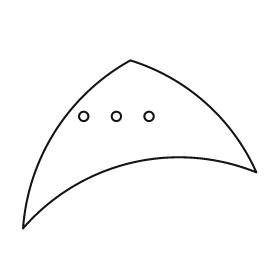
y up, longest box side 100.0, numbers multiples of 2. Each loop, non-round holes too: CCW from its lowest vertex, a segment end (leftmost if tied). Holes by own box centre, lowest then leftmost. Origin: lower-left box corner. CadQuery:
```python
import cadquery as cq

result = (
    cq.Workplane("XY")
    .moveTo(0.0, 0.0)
    .threePointArc((46.0, 28.0), (100.0, 24.0))
    .threePointArc((78.0, 54.0), (46.0, 72.0))
    .threePointArc((14.0, 42.0), (0.0, 0.0))
    .close()
    .moveTo(26.0, 48.0)
    .circle(2.0)
    .moveTo(40.0, 48.0)
    .circle(2.0)
    .moveTo(54.0, 48.0)
    .circle(2.0)
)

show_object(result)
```